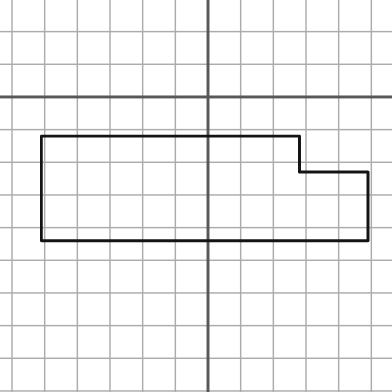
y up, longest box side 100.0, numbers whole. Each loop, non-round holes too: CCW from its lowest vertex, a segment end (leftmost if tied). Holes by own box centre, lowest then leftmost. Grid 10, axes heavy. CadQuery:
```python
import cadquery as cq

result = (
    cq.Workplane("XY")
    .moveTo(-51.0, -44.0)
    .lineTo(49.0, -44.0)
    .lineTo(49.0, -23.0)
    .lineTo(28.0, -23.0)
    .lineTo(28.0, -12.0)
    .lineTo(-51.0, -12.0)
    .close()
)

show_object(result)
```